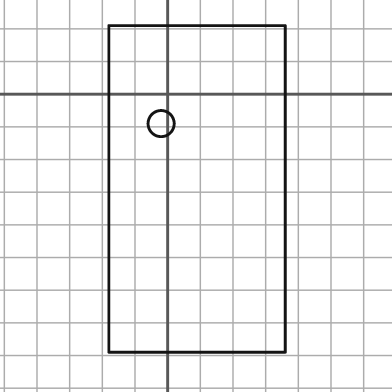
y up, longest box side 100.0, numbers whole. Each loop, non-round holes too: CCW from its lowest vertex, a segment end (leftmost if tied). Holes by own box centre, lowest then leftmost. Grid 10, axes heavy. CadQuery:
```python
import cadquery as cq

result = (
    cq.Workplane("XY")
    .moveTo(-18.0, -79.0)
    .lineTo(36.0, -79.0)
    .lineTo(36.0, 21.0)
    .lineTo(-18.0, 21.0)
    .close()
    .moveTo(-2.0, -9.0)
    .circle(4.0)
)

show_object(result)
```